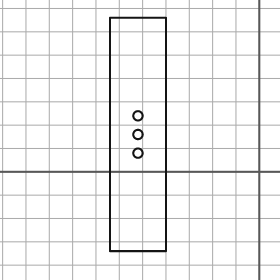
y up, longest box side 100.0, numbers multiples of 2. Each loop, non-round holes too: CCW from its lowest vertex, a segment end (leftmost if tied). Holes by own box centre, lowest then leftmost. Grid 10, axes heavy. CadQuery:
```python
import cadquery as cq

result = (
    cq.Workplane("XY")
    .moveTo(-64.0, -34.0)
    .lineTo(-40.0, -34.0)
    .lineTo(-40.0, 66.0)
    .lineTo(-64.0, 66.0)
    .close()
    .moveTo(-52.0, 8.0)
    .circle(2.0)
    .moveTo(-52.0, 16.0)
    .circle(2.0)
    .moveTo(-52.0, 24.0)
    .circle(2.0)
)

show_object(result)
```